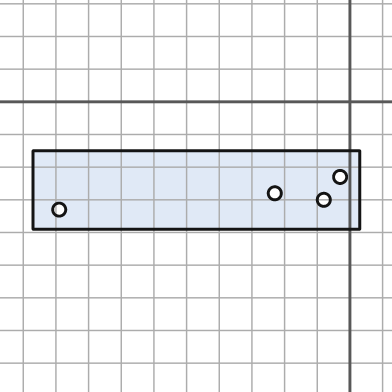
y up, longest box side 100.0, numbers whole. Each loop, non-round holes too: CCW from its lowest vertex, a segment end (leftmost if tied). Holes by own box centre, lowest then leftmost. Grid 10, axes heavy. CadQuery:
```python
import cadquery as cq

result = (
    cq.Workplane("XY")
    .moveTo(-97.0, -39.0)
    .lineTo(3.0, -39.0)
    .lineTo(3.0, -15.0)
    .lineTo(-97.0, -15.0)
    .close()
    .moveTo(-89.0, -33.0)
    .circle(2.0)
    .moveTo(-8.0, -30.0)
    .circle(2.0)
    .moveTo(-23.0, -28.0)
    .circle(2.0)
    .moveTo(-3.0, -23.0)
    .circle(2.0)
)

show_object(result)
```